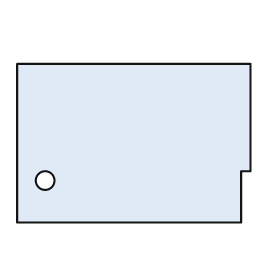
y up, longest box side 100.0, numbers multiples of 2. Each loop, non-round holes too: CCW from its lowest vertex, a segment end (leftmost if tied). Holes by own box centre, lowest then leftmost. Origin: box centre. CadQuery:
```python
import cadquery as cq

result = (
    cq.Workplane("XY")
    .moveTo(-50.0, -34.0)
    .lineTo(46.0, -34.0)
    .lineTo(46.0, -12.0)
    .lineTo(50.0, -12.0)
    .lineTo(50.0, 34.0)
    .lineTo(-50.0, 34.0)
    .close()
    .moveTo(-38.0, -16.0)
    .circle(4.0)
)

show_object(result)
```